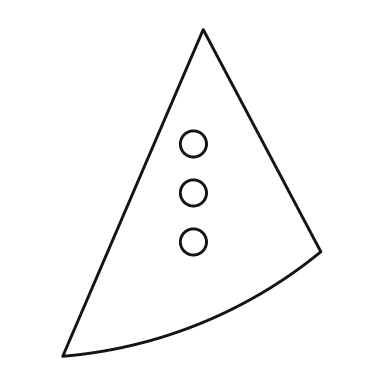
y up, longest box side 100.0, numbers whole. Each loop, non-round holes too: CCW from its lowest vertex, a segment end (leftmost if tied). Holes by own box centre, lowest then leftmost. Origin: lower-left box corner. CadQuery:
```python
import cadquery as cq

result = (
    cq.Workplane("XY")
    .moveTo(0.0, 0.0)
    .threePointArc((42.0, 10.0), (79.0, 32.0))
    .lineTo(43.0, 100.0)
    .close()
    .moveTo(40.0, 35.0)
    .circle(4.0)
    .moveTo(40.0, 50.0)
    .circle(4.0)
    .moveTo(40.0, 65.0)
    .circle(4.0)
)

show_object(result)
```